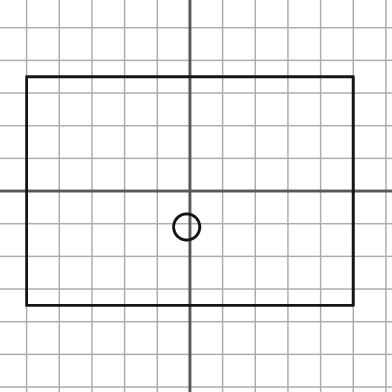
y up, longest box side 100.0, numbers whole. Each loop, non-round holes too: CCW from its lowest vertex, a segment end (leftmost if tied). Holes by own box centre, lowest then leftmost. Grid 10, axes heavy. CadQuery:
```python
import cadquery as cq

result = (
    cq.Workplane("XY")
    .moveTo(-50.0, -35.0)
    .lineTo(50.0, -35.0)
    .lineTo(50.0, 35.0)
    .lineTo(-50.0, 35.0)
    .close()
    .moveTo(-1.0, -11.0)
    .circle(4.0)
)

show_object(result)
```